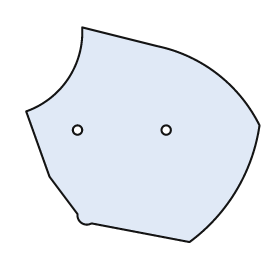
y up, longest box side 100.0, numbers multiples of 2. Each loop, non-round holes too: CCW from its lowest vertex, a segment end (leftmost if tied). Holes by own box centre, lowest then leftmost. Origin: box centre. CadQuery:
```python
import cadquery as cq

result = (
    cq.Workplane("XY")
    .moveTo(20.0, -46.0)
    .threePointArc((40.0, -24.0), (50.0, 4.0))
    .threePointArc((32.0, 26.0), (6.0, 38.0))
    .lineTo(-26.0, 46.0)
    .threePointArc((-32.0, 24.0), (-50.0, 10.0))
    .lineTo(-40.0, -18.0)
    .lineTo(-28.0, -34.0)
    .threePointArc((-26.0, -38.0), (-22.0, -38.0))
    .close()
    .moveTo(-28.0, 2.0)
    .circle(2.0)
    .moveTo(10.0, 2.0)
    .circle(2.0)
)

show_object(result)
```